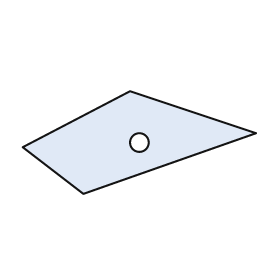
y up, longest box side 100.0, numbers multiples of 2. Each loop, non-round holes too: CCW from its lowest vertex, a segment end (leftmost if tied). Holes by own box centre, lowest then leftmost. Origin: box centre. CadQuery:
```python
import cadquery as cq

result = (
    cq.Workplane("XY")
    .moveTo(-24.0, -22.0)
    .lineTo(50.0, 4.0)
    .lineTo(-4.0, 22.0)
    .lineTo(-50.0, -2.0)
    .close()
    .moveTo(0.0, 0.0)
    .circle(4.0)
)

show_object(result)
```